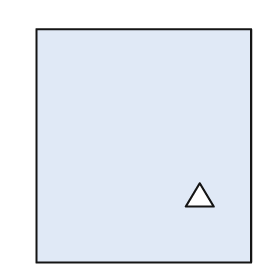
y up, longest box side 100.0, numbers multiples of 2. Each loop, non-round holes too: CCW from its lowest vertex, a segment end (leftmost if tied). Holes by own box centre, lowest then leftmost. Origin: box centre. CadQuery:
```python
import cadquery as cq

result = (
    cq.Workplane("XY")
    .moveTo(-46.0, -50.0)
    .lineTo(46.0, -50.0)
    .lineTo(46.0, 50.0)
    .lineTo(-46.0, 50.0)
    .close()
    .moveTo(18.0, -26.0)
    .lineTo(30.0, -26.0)
    .lineTo(24.0, -16.0)
    .close()
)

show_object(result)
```